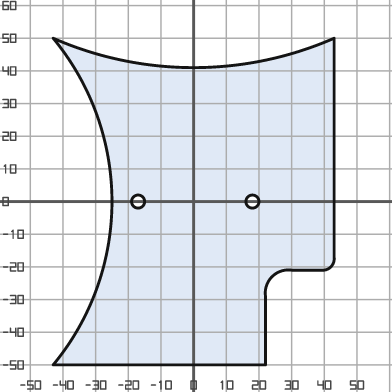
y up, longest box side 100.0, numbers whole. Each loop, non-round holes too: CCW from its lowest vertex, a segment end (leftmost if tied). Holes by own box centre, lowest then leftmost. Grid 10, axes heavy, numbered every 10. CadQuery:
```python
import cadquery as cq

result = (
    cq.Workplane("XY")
    .moveTo(-43.0, -50.0)
    .lineTo(22.0, -50.0)
    .lineTo(22.0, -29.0)
    .threePointArc((24.0, -23.0), (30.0, -21.0))
    .lineTo(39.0, -21.0)
    .threePointArc((42.0, -20.0), (43.0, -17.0))
    .lineTo(43.0, 50.0)
    .threePointArc((0.0, 41.0), (-43.0, 50.0))
    .threePointArc((-25.0, 0.0), (-43.0, -50.0))
    .close()
    .moveTo(-17.0, 0.0)
    .circle(2.0)
    .moveTo(18.0, 0.0)
    .circle(2.0)
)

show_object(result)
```